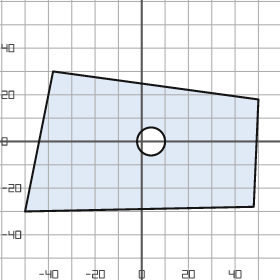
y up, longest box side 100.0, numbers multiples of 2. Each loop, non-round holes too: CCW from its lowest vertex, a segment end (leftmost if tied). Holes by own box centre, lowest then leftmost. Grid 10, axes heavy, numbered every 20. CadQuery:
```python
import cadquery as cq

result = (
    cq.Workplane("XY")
    .moveTo(-50.0, -30.0)
    .lineTo(48.0, -28.0)
    .lineTo(50.0, 18.0)
    .lineTo(-38.0, 30.0)
    .close()
    .moveTo(4.0, 0.0)
    .circle(6.0)
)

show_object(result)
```